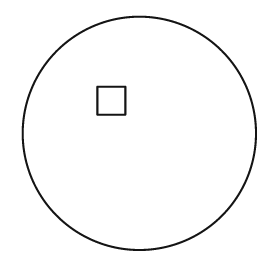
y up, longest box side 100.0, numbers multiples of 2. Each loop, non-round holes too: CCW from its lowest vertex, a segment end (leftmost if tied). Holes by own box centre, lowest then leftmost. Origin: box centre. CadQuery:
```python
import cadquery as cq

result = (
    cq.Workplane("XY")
    .moveTo(0.0, 0.0)
    .circle(50.0)
    .moveTo(-18.0, 8.0)
    .lineTo(-6.0, 8.0)
    .lineTo(-6.0, 20.0)
    .lineTo(-18.0, 20.0)
    .close()
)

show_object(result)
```